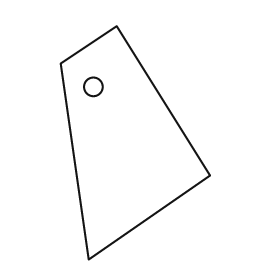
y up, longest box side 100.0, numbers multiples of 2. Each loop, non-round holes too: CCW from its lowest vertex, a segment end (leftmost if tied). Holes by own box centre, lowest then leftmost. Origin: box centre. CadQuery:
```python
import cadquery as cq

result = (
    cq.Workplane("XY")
    .moveTo(-20.0, -50.0)
    .lineTo(32.0, -14.0)
    .lineTo(-8.0, 50.0)
    .lineTo(-32.0, 34.0)
    .close()
    .moveTo(-18.0, 24.0)
    .circle(4.0)
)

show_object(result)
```